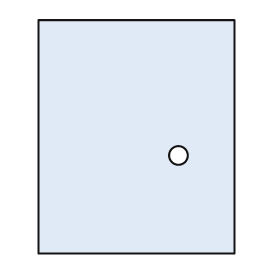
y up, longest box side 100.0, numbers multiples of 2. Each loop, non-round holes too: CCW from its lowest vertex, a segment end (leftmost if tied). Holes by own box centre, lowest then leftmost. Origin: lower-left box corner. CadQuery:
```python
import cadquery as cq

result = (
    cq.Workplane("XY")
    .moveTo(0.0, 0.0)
    .lineTo(84.0, 0.0)
    .lineTo(84.0, 100.0)
    .lineTo(0.0, 100.0)
    .close()
    .moveTo(60.0, 42.0)
    .circle(4.0)
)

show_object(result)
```